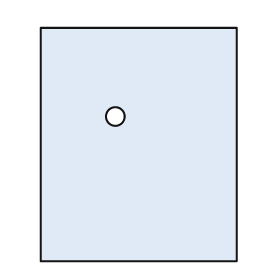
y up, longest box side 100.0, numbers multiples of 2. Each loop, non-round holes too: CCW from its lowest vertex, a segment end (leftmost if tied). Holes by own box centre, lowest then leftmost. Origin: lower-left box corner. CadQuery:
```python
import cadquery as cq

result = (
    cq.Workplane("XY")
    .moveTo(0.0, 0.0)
    .lineTo(84.0, 0.0)
    .lineTo(84.0, 100.0)
    .lineTo(0.0, 100.0)
    .close()
    .moveTo(32.0, 62.0)
    .circle(4.0)
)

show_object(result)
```